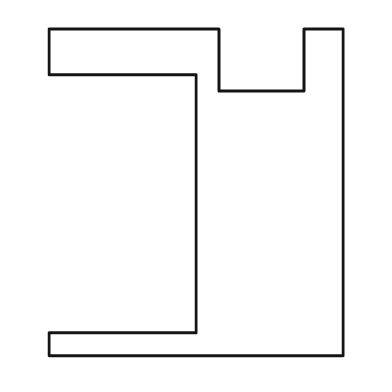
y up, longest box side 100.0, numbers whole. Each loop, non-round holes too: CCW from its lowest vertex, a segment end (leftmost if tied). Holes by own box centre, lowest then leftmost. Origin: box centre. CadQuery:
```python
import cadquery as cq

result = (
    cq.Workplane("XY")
    .moveTo(-45.0, -50.0)
    .lineTo(45.0, -50.0)
    .lineTo(45.0, 50.0)
    .lineTo(33.0, 50.0)
    .lineTo(33.0, 31.0)
    .lineTo(7.0, 31.0)
    .lineTo(7.0, 50.0)
    .lineTo(-45.0, 50.0)
    .lineTo(-45.0, 36.0)
    .lineTo(0.0, 36.0)
    .lineTo(0.0, -43.0)
    .lineTo(-45.0, -43.0)
    .close()
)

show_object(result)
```